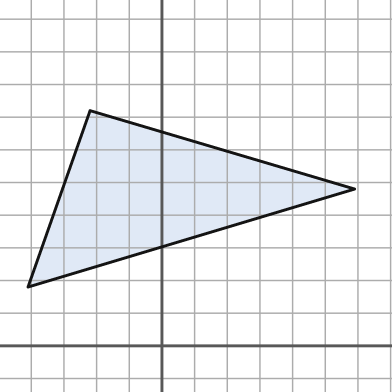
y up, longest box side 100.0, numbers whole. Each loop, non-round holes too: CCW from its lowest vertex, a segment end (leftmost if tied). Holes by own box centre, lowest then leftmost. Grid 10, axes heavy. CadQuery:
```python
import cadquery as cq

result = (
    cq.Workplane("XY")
    .moveTo(-41.0, 18.0)
    .lineTo(59.0, 48.0)
    .lineTo(-22.0, 72.0)
    .close()
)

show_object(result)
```